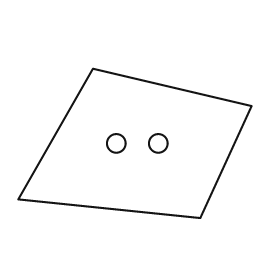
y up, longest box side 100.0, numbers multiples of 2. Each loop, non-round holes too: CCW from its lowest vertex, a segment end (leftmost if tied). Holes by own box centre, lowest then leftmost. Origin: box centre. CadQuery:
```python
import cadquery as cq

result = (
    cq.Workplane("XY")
    .moveTo(28.0, -32.0)
    .lineTo(50.0, 16.0)
    .lineTo(-18.0, 32.0)
    .lineTo(-50.0, -24.0)
    .close()
    .moveTo(-8.0, 0.0)
    .circle(4.0)
    .moveTo(10.0, 0.0)
    .circle(4.0)
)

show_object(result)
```